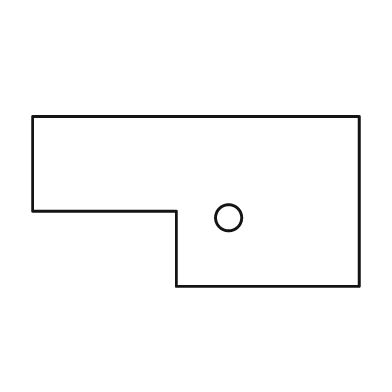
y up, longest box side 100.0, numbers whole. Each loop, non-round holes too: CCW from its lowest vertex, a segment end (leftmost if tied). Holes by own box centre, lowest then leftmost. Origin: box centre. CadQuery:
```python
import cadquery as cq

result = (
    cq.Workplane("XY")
    .moveTo(-6.0, -26.0)
    .lineTo(50.0, -26.0)
    .lineTo(50.0, 26.0)
    .lineTo(-50.0, 26.0)
    .lineTo(-50.0, -3.0)
    .lineTo(-6.0, -3.0)
    .close()
    .moveTo(10.0, -5.0)
    .circle(4.0)
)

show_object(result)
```